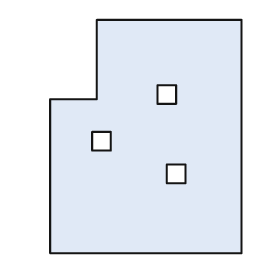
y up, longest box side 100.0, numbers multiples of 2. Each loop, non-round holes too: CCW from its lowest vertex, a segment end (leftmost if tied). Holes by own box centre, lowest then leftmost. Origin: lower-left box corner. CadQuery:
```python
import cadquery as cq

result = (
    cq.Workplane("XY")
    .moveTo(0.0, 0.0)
    .lineTo(82.0, 0.0)
    .lineTo(82.0, 100.0)
    .lineTo(20.0, 100.0)
    .lineTo(20.0, 66.0)
    .lineTo(0.0, 66.0)
    .close()
    .moveTo(50.0, 30.0)
    .lineTo(58.0, 30.0)
    .lineTo(58.0, 38.0)
    .lineTo(50.0, 38.0)
    .close()
    .moveTo(18.0, 44.0)
    .lineTo(26.0, 44.0)
    .lineTo(26.0, 52.0)
    .lineTo(18.0, 52.0)
    .close()
    .moveTo(46.0, 64.0)
    .lineTo(54.0, 64.0)
    .lineTo(54.0, 72.0)
    .lineTo(46.0, 72.0)
    .close()
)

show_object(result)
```